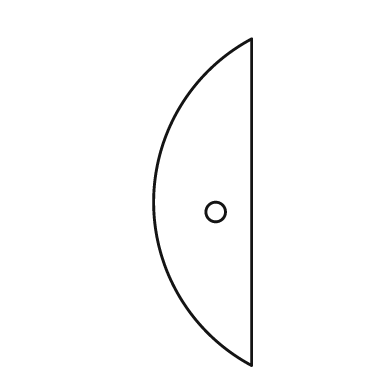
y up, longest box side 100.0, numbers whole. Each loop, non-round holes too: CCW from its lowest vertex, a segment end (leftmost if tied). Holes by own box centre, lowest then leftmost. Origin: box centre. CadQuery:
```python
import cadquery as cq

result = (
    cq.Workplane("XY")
    .moveTo(15.0, -50.0)
    .lineTo(15.0, 50.0)
    .threePointArc((-15.0, 0.0), (15.0, -50.0))
    .close()
    .moveTo(4.0, -3.0)
    .circle(3.0)
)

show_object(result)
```